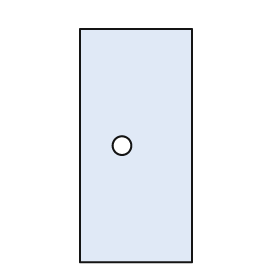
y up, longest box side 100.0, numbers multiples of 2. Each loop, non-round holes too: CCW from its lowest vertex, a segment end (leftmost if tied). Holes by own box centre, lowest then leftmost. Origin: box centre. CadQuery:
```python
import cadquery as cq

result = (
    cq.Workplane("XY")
    .moveTo(-24.0, -50.0)
    .lineTo(24.0, -50.0)
    .lineTo(24.0, 50.0)
    .lineTo(-24.0, 50.0)
    .close()
    .moveTo(-6.0, 0.0)
    .circle(4.0)
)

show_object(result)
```